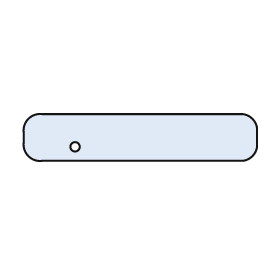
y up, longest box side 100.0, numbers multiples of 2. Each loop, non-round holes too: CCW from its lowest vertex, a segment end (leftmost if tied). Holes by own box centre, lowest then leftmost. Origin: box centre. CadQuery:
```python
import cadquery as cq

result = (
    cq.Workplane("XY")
    .moveTo(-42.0, -10.0)
    .lineTo(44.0, -10.0)
    .threePointArc((48.0, -8.0), (50.0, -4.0))
    .lineTo(50.0, 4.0)
    .threePointArc((48.0, 8.0), (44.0, 10.0))
    .lineTo(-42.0, 10.0)
    .threePointArc((-48.0, 8.0), (-50.0, 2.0))
    .lineTo(-50.0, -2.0)
    .threePointArc((-48.0, -8.0), (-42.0, -10.0))
    .close()
    .moveTo(-28.0, -4.0)
    .circle(2.0)
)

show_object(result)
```